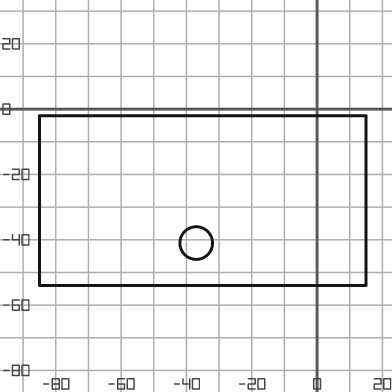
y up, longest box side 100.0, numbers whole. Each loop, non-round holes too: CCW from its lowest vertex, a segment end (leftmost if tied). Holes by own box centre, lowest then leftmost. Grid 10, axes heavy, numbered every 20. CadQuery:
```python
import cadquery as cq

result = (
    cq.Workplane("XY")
    .moveTo(-85.0, -54.0)
    .lineTo(15.0, -54.0)
    .lineTo(15.0, -2.0)
    .lineTo(-85.0, -2.0)
    .close()
    .moveTo(-37.0, -41.0)
    .circle(5.0)
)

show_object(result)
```